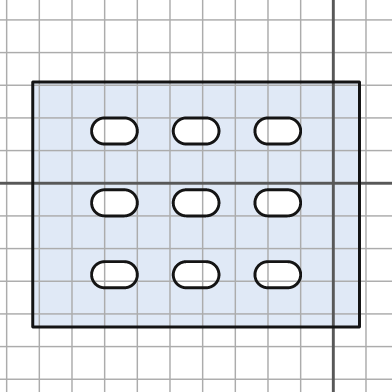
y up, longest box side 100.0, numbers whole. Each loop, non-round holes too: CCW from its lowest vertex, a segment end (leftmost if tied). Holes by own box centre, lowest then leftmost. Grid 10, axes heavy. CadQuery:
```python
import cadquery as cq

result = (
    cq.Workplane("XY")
    .moveTo(-92.0, -44.0)
    .lineTo(8.0, -44.0)
    .lineTo(8.0, 31.0)
    .lineTo(-92.0, 31.0)
    .close()
    .moveTo(-70.0, -32.0)
    .lineTo(-64.0, -32.0)
    .threePointArc((-60.0, -28.0), (-64.0, -24.0))
    .lineTo(-70.0, -24.0)
    .threePointArc((-74.0, -28.0), (-70.0, -32.0))
    .close()
    .moveTo(-45.0, -32.0)
    .lineTo(-39.0, -32.0)
    .threePointArc((-35.0, -28.0), (-39.0, -24.0))
    .lineTo(-45.0, -24.0)
    .threePointArc((-49.0, -28.0), (-45.0, -32.0))
    .close()
    .moveTo(-20.0, -32.0)
    .lineTo(-14.0, -32.0)
    .threePointArc((-10.0, -28.0), (-14.0, -24.0))
    .lineTo(-20.0, -24.0)
    .threePointArc((-24.0, -28.0), (-20.0, -32.0))
    .close()
    .moveTo(-70.0, -10.0)
    .lineTo(-64.0, -10.0)
    .threePointArc((-60.0, -6.0), (-64.0, -2.0))
    .lineTo(-70.0, -2.0)
    .threePointArc((-74.0, -6.0), (-70.0, -10.0))
    .close()
    .moveTo(-45.0, -10.0)
    .lineTo(-39.0, -10.0)
    .threePointArc((-35.0, -6.0), (-39.0, -2.0))
    .lineTo(-45.0, -2.0)
    .threePointArc((-49.0, -6.0), (-45.0, -10.0))
    .close()
    .moveTo(-20.0, -10.0)
    .lineTo(-14.0, -10.0)
    .threePointArc((-10.0, -6.0), (-14.0, -2.0))
    .lineTo(-20.0, -2.0)
    .threePointArc((-24.0, -6.0), (-20.0, -10.0))
    .close()
    .moveTo(-70.0, 12.0)
    .lineTo(-64.0, 12.0)
    .threePointArc((-60.0, 16.0), (-64.0, 20.0))
    .lineTo(-70.0, 20.0)
    .threePointArc((-74.0, 16.0), (-70.0, 12.0))
    .close()
    .moveTo(-45.0, 12.0)
    .lineTo(-39.0, 12.0)
    .threePointArc((-35.0, 16.0), (-39.0, 20.0))
    .lineTo(-45.0, 20.0)
    .threePointArc((-49.0, 16.0), (-45.0, 12.0))
    .close()
    .moveTo(-20.0, 12.0)
    .lineTo(-14.0, 12.0)
    .threePointArc((-10.0, 16.0), (-14.0, 20.0))
    .lineTo(-20.0, 20.0)
    .threePointArc((-24.0, 16.0), (-20.0, 12.0))
    .close()
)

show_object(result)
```